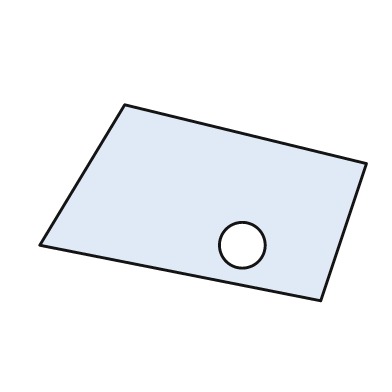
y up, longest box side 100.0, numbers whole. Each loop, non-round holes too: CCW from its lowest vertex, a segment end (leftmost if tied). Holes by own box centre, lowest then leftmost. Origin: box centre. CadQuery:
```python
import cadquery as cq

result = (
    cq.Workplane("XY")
    .moveTo(36.0, -30.0)
    .lineTo(50.0, 12.0)
    .lineTo(-24.0, 30.0)
    .lineTo(-50.0, -13.0)
    .close()
    .moveTo(12.0, -13.0)
    .circle(7.0)
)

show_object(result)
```